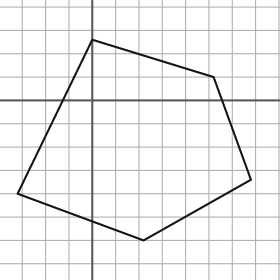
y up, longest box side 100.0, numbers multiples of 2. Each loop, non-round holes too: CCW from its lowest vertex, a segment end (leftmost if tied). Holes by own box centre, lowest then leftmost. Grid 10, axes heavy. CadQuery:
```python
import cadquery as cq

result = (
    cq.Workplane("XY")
    .moveTo(22.0, -60.0)
    .lineTo(68.0, -34.0)
    .lineTo(52.0, 10.0)
    .lineTo(0.0, 26.0)
    .lineTo(-32.0, -40.0)
    .close()
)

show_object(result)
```